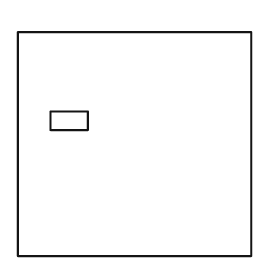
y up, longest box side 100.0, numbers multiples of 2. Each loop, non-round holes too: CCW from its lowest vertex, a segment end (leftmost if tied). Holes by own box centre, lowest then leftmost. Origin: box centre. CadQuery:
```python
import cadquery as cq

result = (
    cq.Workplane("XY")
    .moveTo(-50.0, -48.0)
    .lineTo(50.0, -48.0)
    .lineTo(50.0, 48.0)
    .lineTo(-50.0, 48.0)
    .close()
    .moveTo(-36.0, 6.0)
    .lineTo(-20.0, 6.0)
    .lineTo(-20.0, 14.0)
    .lineTo(-36.0, 14.0)
    .close()
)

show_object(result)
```